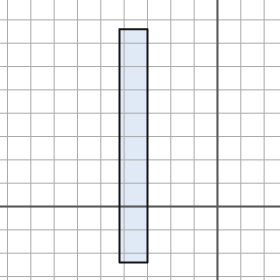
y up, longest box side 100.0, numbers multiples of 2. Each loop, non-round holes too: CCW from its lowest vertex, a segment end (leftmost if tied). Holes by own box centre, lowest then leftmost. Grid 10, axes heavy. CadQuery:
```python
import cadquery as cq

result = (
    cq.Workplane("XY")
    .moveTo(-42.0, -24.0)
    .lineTo(-30.0, -24.0)
    .lineTo(-30.0, 76.0)
    .lineTo(-42.0, 76.0)
    .close()
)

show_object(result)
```